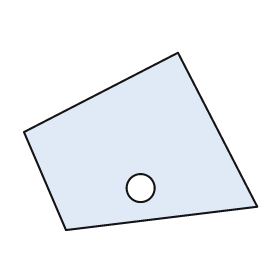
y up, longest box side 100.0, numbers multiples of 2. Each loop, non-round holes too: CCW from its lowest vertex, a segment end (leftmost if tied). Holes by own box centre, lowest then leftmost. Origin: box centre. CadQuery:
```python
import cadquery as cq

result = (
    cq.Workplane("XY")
    .moveTo(-32.0, -38.0)
    .lineTo(50.0, -28.0)
    .lineTo(16.0, 38.0)
    .lineTo(-50.0, 4.0)
    .close()
    .moveTo(0.0, -20.0)
    .circle(6.0)
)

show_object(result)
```